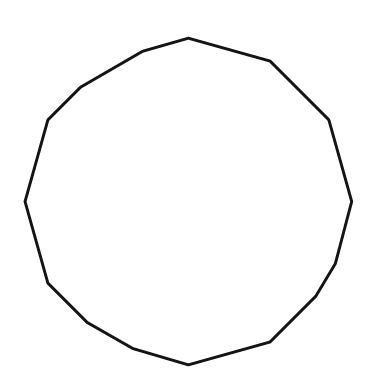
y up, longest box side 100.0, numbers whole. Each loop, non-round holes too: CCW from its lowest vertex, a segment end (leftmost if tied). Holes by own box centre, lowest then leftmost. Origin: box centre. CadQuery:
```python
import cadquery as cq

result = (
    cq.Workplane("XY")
    .moveTo(0.0, -50.0)
    .lineTo(25.0, -43.0)
    .lineTo(39.0, -29.0)
    .lineTo(45.0, -19.0)
    .lineTo(50.0, 0.0)
    .lineTo(43.0, 25.0)
    .lineTo(25.0, 43.0)
    .lineTo(0.0, 50.0)
    .lineTo(-14.0, 46.0)
    .lineTo(-33.0, 35.0)
    .lineTo(-43.0, 25.0)
    .lineTo(-50.0, 0.0)
    .lineTo(-43.0, -25.0)
    .lineTo(-31.0, -37.0)
    .lineTo(-17.0, -45.0)
    .close()
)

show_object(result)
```